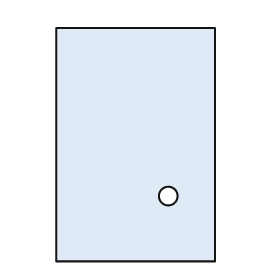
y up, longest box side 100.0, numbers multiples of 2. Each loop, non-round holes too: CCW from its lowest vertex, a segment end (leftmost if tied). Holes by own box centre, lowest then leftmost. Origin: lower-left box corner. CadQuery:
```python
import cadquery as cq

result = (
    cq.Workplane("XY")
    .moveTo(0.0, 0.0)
    .lineTo(68.0, 0.0)
    .lineTo(68.0, 100.0)
    .lineTo(0.0, 100.0)
    .close()
    .moveTo(48.0, 28.0)
    .circle(4.0)
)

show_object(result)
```